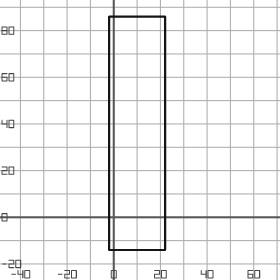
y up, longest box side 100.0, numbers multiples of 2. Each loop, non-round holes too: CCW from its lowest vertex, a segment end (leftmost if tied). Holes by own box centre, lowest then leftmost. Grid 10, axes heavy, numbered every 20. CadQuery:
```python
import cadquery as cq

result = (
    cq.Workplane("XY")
    .moveTo(-2.0, -14.0)
    .lineTo(22.0, -14.0)
    .lineTo(22.0, 86.0)
    .lineTo(-2.0, 86.0)
    .close()
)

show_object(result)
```